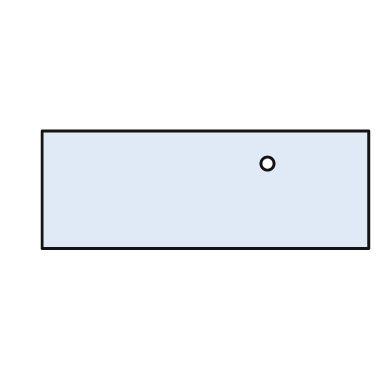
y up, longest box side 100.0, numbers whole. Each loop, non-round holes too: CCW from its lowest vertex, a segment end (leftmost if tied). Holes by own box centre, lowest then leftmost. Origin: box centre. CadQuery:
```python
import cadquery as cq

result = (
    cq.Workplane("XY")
    .moveTo(-50.0, -18.0)
    .lineTo(50.0, -18.0)
    .lineTo(50.0, 18.0)
    .lineTo(-50.0, 18.0)
    .close()
    .moveTo(19.0, 8.0)
    .circle(2.0)
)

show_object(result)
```